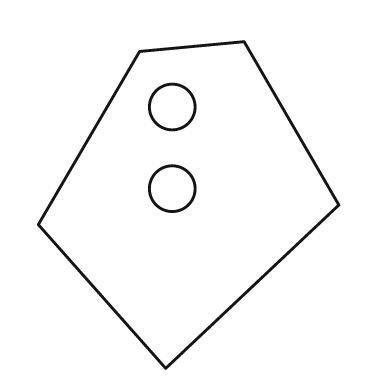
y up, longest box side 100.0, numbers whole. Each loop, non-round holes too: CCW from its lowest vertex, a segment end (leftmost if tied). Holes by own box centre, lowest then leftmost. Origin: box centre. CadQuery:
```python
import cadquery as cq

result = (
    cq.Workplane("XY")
    .moveTo(-7.0, -50.0)
    .lineTo(46.0, 0.0)
    .lineTo(17.0, 50.0)
    .lineTo(-15.0, 47.0)
    .lineTo(-46.0, -6.0)
    .close()
    .moveTo(-5.0, 5.0)
    .circle(7.0)
    .moveTo(-5.0, 30.0)
    .circle(7.0)
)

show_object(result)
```